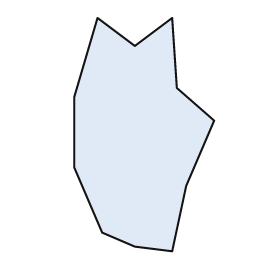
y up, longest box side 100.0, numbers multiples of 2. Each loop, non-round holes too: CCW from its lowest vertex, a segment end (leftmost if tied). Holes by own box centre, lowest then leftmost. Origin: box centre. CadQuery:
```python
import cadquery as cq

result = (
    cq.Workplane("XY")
    .moveTo(12.0, -50.0)
    .lineTo(18.0, -22.0)
    .lineTo(30.0, 6.0)
    .lineTo(14.0, 20.0)
    .lineTo(12.0, 50.0)
    .lineTo(-4.0, 38.0)
    .lineTo(-20.0, 50.0)
    .lineTo(-30.0, 16.0)
    .lineTo(-30.0, -14.0)
    .lineTo(-18.0, -42.0)
    .lineTo(-4.0, -48.0)
    .close()
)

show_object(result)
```